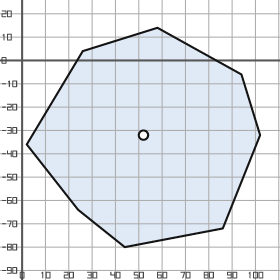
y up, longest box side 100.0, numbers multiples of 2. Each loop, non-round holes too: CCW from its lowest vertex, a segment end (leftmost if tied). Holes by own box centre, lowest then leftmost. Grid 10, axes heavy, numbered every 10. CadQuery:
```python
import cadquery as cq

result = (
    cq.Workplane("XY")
    .moveTo(44.0, -80.0)
    .lineTo(86.0, -72.0)
    .lineTo(102.0, -32.0)
    .lineTo(94.0, -6.0)
    .lineTo(58.0, 14.0)
    .lineTo(26.0, 4.0)
    .lineTo(2.0, -36.0)
    .lineTo(24.0, -64.0)
    .close()
    .moveTo(52.0, -32.0)
    .circle(2.0)
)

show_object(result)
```